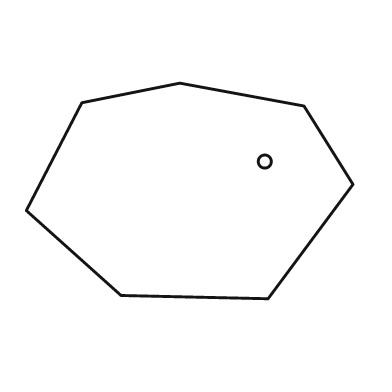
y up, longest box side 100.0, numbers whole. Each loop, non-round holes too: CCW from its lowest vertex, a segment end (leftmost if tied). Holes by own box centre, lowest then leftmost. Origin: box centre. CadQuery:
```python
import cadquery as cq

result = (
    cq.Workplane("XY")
    .moveTo(24.0, -33.0)
    .lineTo(50.0, 2.0)
    .lineTo(35.0, 26.0)
    .lineTo(-3.0, 33.0)
    .lineTo(-33.0, 27.0)
    .lineTo(-50.0, -6.0)
    .lineTo(-21.0, -32.0)
    .close()
    .moveTo(23.0, 9.0)
    .circle(2.0)
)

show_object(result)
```